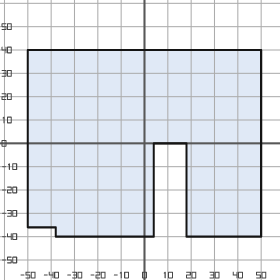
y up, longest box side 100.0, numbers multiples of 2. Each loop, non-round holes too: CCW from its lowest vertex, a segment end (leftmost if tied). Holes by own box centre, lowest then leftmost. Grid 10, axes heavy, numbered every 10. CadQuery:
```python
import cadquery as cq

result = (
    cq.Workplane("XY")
    .moveTo(-38.0, -40.0)
    .lineTo(4.0, -40.0)
    .lineTo(4.0, 0.0)
    .lineTo(18.0, 0.0)
    .lineTo(18.0, -40.0)
    .lineTo(50.0, -40.0)
    .lineTo(50.0, 40.0)
    .lineTo(-50.0, 40.0)
    .lineTo(-50.0, -36.0)
    .lineTo(-38.0, -36.0)
    .close()
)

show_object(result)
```